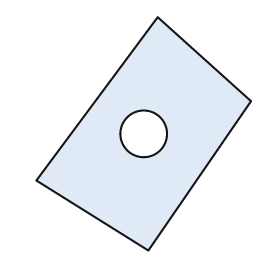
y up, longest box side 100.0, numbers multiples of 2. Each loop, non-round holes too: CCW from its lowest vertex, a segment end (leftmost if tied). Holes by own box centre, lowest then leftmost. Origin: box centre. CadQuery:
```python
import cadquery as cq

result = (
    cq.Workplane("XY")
    .moveTo(2.0, -50.0)
    .lineTo(46.0, 14.0)
    .lineTo(6.0, 50.0)
    .lineTo(-46.0, -20.0)
    .close()
    .moveTo(0.0, 0.0)
    .circle(10.0)
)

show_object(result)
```